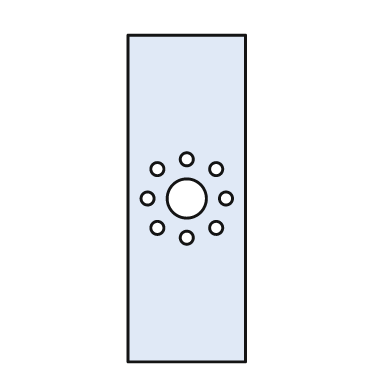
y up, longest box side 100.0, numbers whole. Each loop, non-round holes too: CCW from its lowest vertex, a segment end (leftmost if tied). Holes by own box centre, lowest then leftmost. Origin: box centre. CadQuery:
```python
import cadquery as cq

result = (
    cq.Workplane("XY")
    .moveTo(-18.0, -50.0)
    .lineTo(18.0, -50.0)
    .lineTo(18.0, 50.0)
    .lineTo(-18.0, 50.0)
    .close()
    .moveTo(0.0, -12.0)
    .circle(2.0)
    .moveTo(-9.0, -9.0)
    .circle(2.0)
    .moveTo(9.0, -9.0)
    .circle(2.0)
    .moveTo(-12.0, 0.0)
    .circle(2.0)
    .moveTo(0.0, 0.0)
    .circle(6.0)
    .moveTo(12.0, 0.0)
    .circle(2.0)
    .moveTo(-9.0, 9.0)
    .circle(2.0)
    .moveTo(9.0, 9.0)
    .circle(2.0)
    .moveTo(0.0, 12.0)
    .circle(2.0)
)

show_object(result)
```